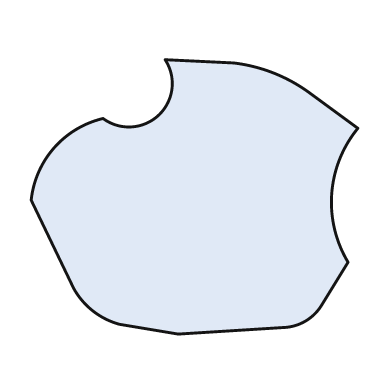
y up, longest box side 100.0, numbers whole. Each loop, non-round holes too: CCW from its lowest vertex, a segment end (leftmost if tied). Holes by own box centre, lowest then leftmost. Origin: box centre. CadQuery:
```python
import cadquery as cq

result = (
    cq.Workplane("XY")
    .moveTo(-5.0, -42.0)
    .lineTo(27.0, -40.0)
    .threePointArc((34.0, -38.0), (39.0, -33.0))
    .lineTo(47.0, -20.0)
    .threePointArc((42.0, 1.0), (50.0, 21.0))
    .lineTo(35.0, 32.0)
    .threePointArc((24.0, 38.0), (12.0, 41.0))
    .lineTo(-9.0, 42.0)
    .threePointArc((-11.0, 25.0), (-28.0, 24.0))
    .threePointArc((-43.0, 15.0), (-50.0, -1.0))
    .lineTo(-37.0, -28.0)
    .threePointArc((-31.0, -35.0), (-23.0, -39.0))
    .close()
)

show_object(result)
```